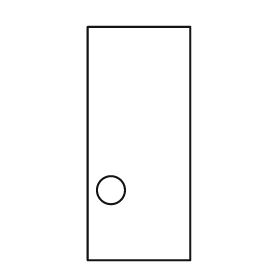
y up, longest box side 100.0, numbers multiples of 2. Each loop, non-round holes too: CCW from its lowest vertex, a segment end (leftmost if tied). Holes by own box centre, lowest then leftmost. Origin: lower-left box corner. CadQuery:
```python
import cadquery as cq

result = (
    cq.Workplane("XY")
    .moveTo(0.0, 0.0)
    .lineTo(44.0, 0.0)
    .lineTo(44.0, 100.0)
    .lineTo(0.0, 100.0)
    .close()
    .moveTo(10.0, 30.0)
    .circle(6.0)
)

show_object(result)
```